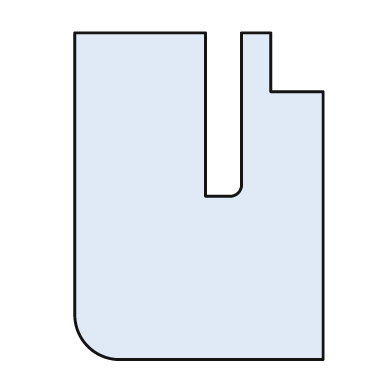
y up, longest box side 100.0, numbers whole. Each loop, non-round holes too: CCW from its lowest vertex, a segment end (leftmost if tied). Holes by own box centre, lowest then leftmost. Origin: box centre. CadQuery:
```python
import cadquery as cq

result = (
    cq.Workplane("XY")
    .moveTo(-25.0, -50.0)
    .lineTo(38.0, -50.0)
    .lineTo(38.0, 32.0)
    .lineTo(22.0, 32.0)
    .lineTo(22.0, 50.0)
    .lineTo(13.0, 50.0)
    .lineTo(13.0, 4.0)
    .threePointArc((12.0, 1.0), (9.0, 0.0))
    .lineTo(2.0, 0.0)
    .lineTo(2.0, 50.0)
    .lineTo(-38.0, 50.0)
    .lineTo(-38.0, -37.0)
    .threePointArc((-34.0, -46.0), (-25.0, -50.0))
    .close()
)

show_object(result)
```